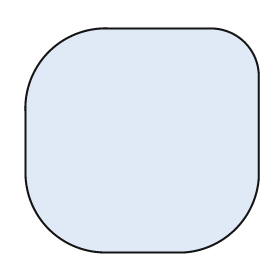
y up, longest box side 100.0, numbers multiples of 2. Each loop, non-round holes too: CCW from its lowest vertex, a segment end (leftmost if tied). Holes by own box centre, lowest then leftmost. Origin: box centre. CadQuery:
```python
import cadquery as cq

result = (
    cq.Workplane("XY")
    .moveTo(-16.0, -48.0)
    .lineTo(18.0, -48.0)
    .threePointArc((40.0, -38.0), (50.0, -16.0))
    .lineTo(50.0, 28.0)
    .threePointArc((44.0, 42.0), (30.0, 48.0))
    .lineTo(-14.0, 48.0)
    .threePointArc((-40.0, 38.0), (-50.0, 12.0))
    .lineTo(-50.0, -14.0)
    .threePointArc((-40.0, -38.0), (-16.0, -48.0))
    .close()
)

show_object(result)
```